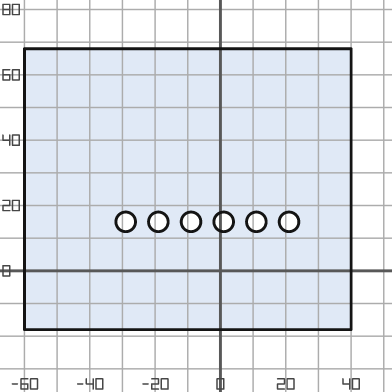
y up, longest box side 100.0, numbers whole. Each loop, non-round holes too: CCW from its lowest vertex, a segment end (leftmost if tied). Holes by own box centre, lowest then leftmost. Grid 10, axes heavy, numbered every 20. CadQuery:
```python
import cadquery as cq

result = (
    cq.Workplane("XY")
    .moveTo(-60.0, -18.0)
    .lineTo(40.0, -18.0)
    .lineTo(40.0, 68.0)
    .lineTo(-60.0, 68.0)
    .close()
    .moveTo(-29.0, 15.0)
    .circle(3.0)
    .moveTo(-19.0, 15.0)
    .circle(3.0)
    .moveTo(-9.0, 15.0)
    .circle(3.0)
    .moveTo(1.0, 15.0)
    .circle(3.0)
    .moveTo(11.0, 15.0)
    .circle(3.0)
    .moveTo(21.0, 15.0)
    .circle(3.0)
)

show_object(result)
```